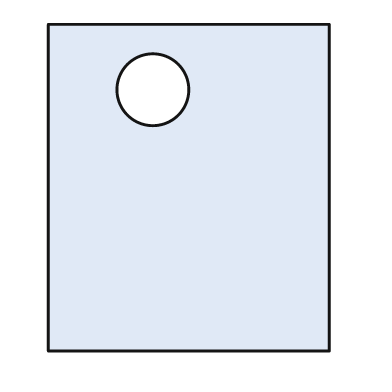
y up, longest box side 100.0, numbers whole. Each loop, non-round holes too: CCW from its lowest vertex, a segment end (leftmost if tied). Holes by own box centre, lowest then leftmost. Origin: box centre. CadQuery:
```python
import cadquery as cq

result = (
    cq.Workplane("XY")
    .moveTo(-43.0, -50.0)
    .lineTo(43.0, -50.0)
    .lineTo(43.0, 50.0)
    .lineTo(-43.0, 50.0)
    .close()
    .moveTo(-11.0, 30.0)
    .circle(11.0)
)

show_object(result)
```